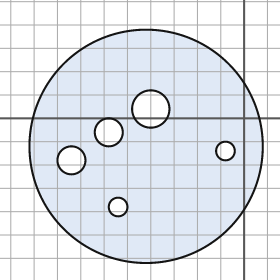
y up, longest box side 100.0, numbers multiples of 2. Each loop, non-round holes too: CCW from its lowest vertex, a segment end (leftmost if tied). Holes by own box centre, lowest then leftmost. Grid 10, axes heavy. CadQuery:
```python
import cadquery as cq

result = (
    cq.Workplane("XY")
    .moveTo(-42.0, -12.0)
    .circle(50.0)
    .moveTo(-54.0, -38.0)
    .circle(4.0)
    .moveTo(-74.0, -18.0)
    .circle(6.0)
    .moveTo(-8.0, -14.0)
    .circle(4.0)
    .moveTo(-58.0, -6.0)
    .circle(6.0)
    .moveTo(-40.0, 4.0)
    .circle(8.0)
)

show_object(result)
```